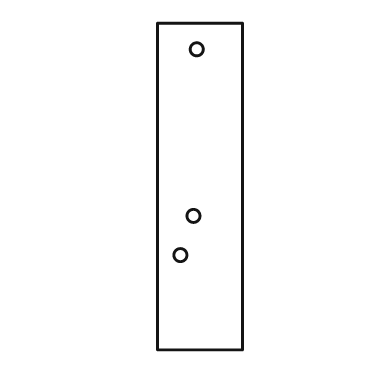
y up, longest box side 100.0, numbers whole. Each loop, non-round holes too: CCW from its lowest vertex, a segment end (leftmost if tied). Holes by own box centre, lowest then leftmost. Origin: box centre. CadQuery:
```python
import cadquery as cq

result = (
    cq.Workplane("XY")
    .moveTo(-13.0, -50.0)
    .lineTo(13.0, -50.0)
    .lineTo(13.0, 50.0)
    .lineTo(-13.0, 50.0)
    .close()
    .moveTo(-6.0, -21.0)
    .circle(2.0)
    .moveTo(-2.0, -9.0)
    .circle(2.0)
    .moveTo(-1.0, 42.0)
    .circle(2.0)
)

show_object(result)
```